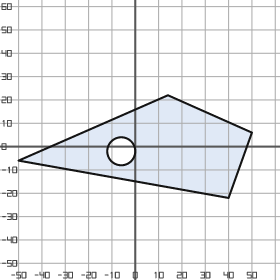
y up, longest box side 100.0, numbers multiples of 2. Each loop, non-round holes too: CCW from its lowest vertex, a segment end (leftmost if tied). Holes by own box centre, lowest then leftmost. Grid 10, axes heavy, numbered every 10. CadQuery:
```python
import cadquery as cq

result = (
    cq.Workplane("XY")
    .moveTo(40.0, -22.0)
    .lineTo(50.0, 6.0)
    .lineTo(14.0, 22.0)
    .lineTo(-50.0, -6.0)
    .close()
    .moveTo(-6.0, -2.0)
    .circle(6.0)
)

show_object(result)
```